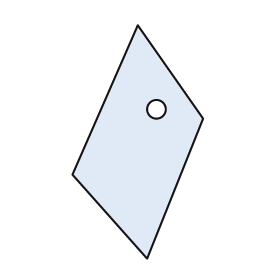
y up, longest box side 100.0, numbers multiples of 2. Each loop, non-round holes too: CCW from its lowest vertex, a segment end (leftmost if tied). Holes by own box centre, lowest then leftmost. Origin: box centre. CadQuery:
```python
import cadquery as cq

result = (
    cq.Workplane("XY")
    .moveTo(4.0, -50.0)
    .lineTo(28.0, 10.0)
    .lineTo(0.0, 50.0)
    .lineTo(-28.0, -14.0)
    .close()
    .moveTo(8.0, 14.0)
    .circle(4.0)
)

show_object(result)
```